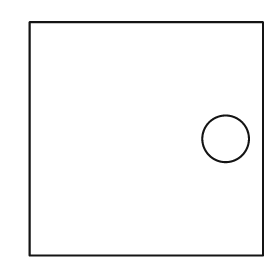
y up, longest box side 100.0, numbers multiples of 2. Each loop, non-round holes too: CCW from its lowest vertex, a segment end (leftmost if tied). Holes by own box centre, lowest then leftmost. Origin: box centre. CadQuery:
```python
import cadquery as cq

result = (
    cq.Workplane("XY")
    .moveTo(-50.0, -50.0)
    .lineTo(50.0, -50.0)
    .lineTo(50.0, 50.0)
    .lineTo(-50.0, 50.0)
    .close()
    .moveTo(34.0, 0.0)
    .circle(10.0)
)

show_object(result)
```